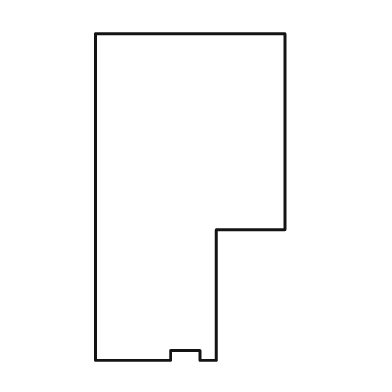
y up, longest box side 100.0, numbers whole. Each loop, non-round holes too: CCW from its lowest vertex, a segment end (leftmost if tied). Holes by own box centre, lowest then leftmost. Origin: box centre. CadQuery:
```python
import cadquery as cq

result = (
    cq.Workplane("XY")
    .moveTo(-29.0, -50.0)
    .lineTo(-6.0, -50.0)
    .lineTo(-6.0, -47.0)
    .lineTo(3.0, -47.0)
    .lineTo(3.0, -50.0)
    .lineTo(8.0, -50.0)
    .lineTo(8.0, -10.0)
    .lineTo(29.0, -10.0)
    .lineTo(29.0, 50.0)
    .lineTo(-29.0, 50.0)
    .close()
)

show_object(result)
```